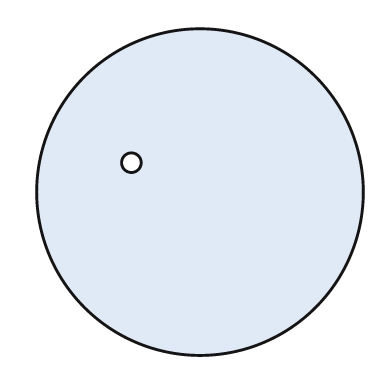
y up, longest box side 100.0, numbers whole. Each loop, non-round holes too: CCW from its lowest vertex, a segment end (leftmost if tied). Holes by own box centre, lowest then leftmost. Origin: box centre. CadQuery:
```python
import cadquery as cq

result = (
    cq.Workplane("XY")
    .moveTo(0.0, 0.0)
    .circle(50.0)
    .moveTo(-21.0, 9.0)
    .circle(3.0)
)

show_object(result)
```